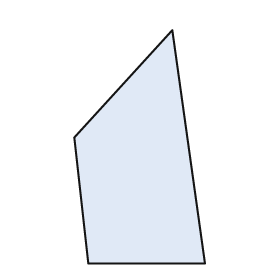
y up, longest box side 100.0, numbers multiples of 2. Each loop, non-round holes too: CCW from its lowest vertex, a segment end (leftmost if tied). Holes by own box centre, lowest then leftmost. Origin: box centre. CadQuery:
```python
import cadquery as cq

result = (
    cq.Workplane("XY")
    .moveTo(-22.0, -50.0)
    .lineTo(28.0, -50.0)
    .lineTo(14.0, 50.0)
    .lineTo(-28.0, 4.0)
    .close()
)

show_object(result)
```